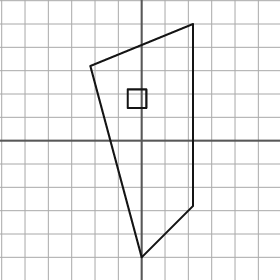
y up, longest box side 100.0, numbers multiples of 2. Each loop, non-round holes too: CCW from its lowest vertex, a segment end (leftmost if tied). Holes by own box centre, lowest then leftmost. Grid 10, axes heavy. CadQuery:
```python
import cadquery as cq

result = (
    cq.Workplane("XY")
    .moveTo(0.0, -50.0)
    .lineTo(22.0, -28.0)
    .lineTo(22.0, 50.0)
    .lineTo(-22.0, 32.0)
    .close()
    .moveTo(-6.0, 14.0)
    .lineTo(2.0, 14.0)
    .lineTo(2.0, 22.0)
    .lineTo(-6.0, 22.0)
    .close()
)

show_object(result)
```